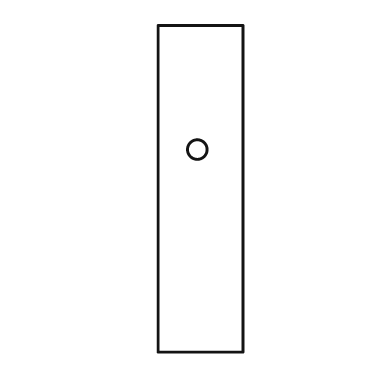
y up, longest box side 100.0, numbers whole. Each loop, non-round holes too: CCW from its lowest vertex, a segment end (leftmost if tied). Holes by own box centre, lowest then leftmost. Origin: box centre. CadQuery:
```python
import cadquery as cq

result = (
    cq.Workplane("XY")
    .moveTo(-13.0, -50.0)
    .lineTo(13.0, -50.0)
    .lineTo(13.0, 50.0)
    .lineTo(-13.0, 50.0)
    .close()
    .moveTo(-1.0, 12.0)
    .circle(3.0)
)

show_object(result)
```